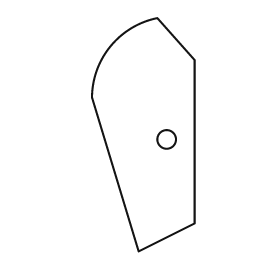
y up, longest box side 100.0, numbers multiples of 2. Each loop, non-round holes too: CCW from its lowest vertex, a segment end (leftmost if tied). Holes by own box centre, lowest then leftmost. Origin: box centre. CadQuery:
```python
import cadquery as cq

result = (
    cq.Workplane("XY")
    .moveTo(-2.0, -50.0)
    .lineTo(22.0, -38.0)
    .lineTo(22.0, 32.0)
    .lineTo(6.0, 50.0)
    .threePointArc((-14.0, 38.0), (-22.0, 16.0))
    .close()
    .moveTo(10.0, -2.0)
    .circle(4.0)
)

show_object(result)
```